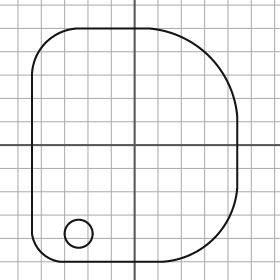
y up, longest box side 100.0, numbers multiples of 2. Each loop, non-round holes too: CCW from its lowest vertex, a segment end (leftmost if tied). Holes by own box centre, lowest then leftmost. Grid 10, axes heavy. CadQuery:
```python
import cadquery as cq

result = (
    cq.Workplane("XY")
    .moveTo(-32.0, -50.0)
    .lineTo(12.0, -50.0)
    .threePointArc((34.0, -40.0), (44.0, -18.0))
    .lineTo(44.0, 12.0)
    .threePointArc((32.0, 38.0), (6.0, 50.0))
    .lineTo(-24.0, 50.0)
    .threePointArc((-38.0, 44.0), (-44.0, 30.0))
    .lineTo(-44.0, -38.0)
    .threePointArc((-40.0, -46.0), (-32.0, -50.0))
    .close()
    .moveTo(-24.0, -38.0)
    .circle(6.0)
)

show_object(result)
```